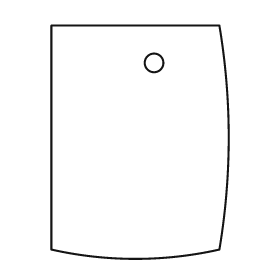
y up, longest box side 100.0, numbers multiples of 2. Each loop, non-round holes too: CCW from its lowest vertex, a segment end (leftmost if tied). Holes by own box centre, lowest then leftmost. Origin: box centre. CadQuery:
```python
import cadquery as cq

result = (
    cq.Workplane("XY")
    .moveTo(-38.0, -46.0)
    .threePointArc((-2.0, -50.0), (34.0, -46.0))
    .threePointArc((38.0, 2.0), (34.0, 50.0))
    .lineTo(-38.0, 50.0)
    .close()
    .moveTo(6.0, 34.0)
    .circle(4.0)
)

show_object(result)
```